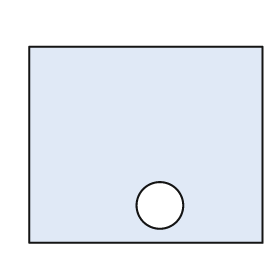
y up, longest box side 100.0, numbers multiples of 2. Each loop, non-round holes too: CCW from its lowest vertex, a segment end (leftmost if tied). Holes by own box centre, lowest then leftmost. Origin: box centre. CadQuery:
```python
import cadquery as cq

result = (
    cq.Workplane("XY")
    .moveTo(-50.0, -42.0)
    .lineTo(50.0, -42.0)
    .lineTo(50.0, 42.0)
    .lineTo(-50.0, 42.0)
    .close()
    .moveTo(6.0, -26.0)
    .circle(10.0)
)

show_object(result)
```